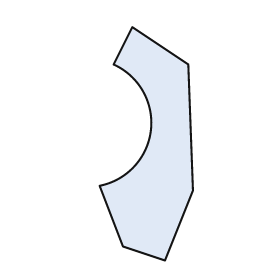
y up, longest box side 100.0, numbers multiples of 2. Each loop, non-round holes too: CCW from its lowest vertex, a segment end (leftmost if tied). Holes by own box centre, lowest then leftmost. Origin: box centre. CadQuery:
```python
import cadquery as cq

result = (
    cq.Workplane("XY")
    .moveTo(8.0, -50.0)
    .lineTo(20.0, -20.0)
    .lineTo(18.0, 34.0)
    .lineTo(-6.0, 50.0)
    .lineTo(-14.0, 34.0)
    .threePointArc((2.0, 6.0), (-20.0, -18.0))
    .lineTo(-10.0, -44.0)
    .close()
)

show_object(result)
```